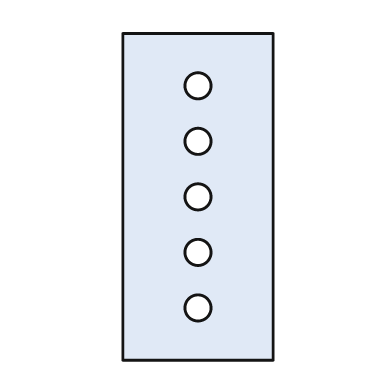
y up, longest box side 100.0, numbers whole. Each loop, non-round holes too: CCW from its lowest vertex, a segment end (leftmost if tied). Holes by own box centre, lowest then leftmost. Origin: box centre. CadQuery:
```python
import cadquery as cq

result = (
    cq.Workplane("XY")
    .moveTo(-23.0, -50.0)
    .lineTo(23.0, -50.0)
    .lineTo(23.0, 50.0)
    .lineTo(-23.0, 50.0)
    .close()
    .moveTo(0.0, -34.0)
    .circle(4.0)
    .moveTo(0.0, -17.0)
    .circle(4.0)
    .moveTo(0.0, 0.0)
    .circle(4.0)
    .moveTo(0.0, 17.0)
    .circle(4.0)
    .moveTo(0.0, 34.0)
    .circle(4.0)
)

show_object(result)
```